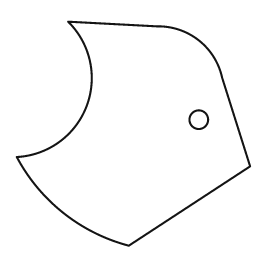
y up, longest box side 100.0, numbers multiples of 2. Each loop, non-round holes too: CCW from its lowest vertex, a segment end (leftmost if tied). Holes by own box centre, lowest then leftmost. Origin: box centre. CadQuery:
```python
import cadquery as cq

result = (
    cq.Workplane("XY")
    .moveTo(-2.0, -48.0)
    .lineTo(50.0, -14.0)
    .lineTo(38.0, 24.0)
    .threePointArc((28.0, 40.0), (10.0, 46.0))
    .lineTo(-28.0, 48.0)
    .threePointArc((-20.0, 12.0), (-50.0, -10.0))
    .threePointArc((-30.0, -34.0), (-2.0, -48.0))
    .close()
    .moveTo(28.0, 6.0)
    .circle(4.0)
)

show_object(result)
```